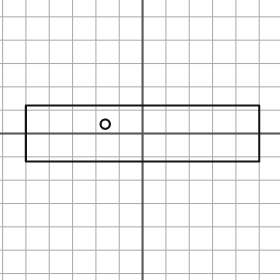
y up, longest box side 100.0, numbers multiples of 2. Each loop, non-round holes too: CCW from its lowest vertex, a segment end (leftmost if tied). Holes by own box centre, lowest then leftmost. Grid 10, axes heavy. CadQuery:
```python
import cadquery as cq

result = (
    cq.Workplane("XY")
    .moveTo(-50.0, -12.0)
    .lineTo(50.0, -12.0)
    .lineTo(50.0, 12.0)
    .lineTo(-50.0, 12.0)
    .close()
    .moveTo(-16.0, 4.0)
    .circle(2.0)
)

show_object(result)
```